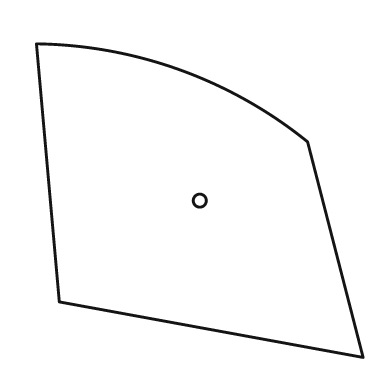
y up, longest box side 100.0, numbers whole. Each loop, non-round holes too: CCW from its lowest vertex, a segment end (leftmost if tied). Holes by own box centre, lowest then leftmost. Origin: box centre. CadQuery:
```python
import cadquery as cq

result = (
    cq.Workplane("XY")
    .moveTo(50.0, -48.0)
    .lineTo(33.0, 18.0)
    .threePointArc((-6.0, 40.0), (-50.0, 48.0))
    .lineTo(-43.0, -31.0)
    .close()
    .moveTo(0.0, 0.0)
    .circle(2.0)
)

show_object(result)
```